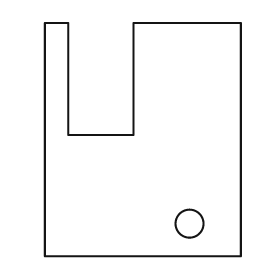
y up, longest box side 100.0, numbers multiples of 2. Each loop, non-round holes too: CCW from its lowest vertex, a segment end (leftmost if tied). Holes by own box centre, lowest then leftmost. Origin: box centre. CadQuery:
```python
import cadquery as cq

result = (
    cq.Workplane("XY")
    .moveTo(-42.0, -50.0)
    .lineTo(42.0, -50.0)
    .lineTo(42.0, 50.0)
    .lineTo(-4.0, 50.0)
    .lineTo(-4.0, 2.0)
    .lineTo(-32.0, 2.0)
    .lineTo(-32.0, 50.0)
    .lineTo(-42.0, 50.0)
    .close()
    .moveTo(20.0, -36.0)
    .circle(6.0)
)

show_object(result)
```